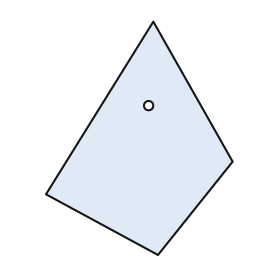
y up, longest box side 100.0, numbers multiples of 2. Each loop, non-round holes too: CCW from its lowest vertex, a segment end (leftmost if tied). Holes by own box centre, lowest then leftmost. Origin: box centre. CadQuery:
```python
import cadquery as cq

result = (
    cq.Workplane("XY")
    .moveTo(8.0, -50.0)
    .lineTo(40.0, -10.0)
    .lineTo(6.0, 50.0)
    .lineTo(-40.0, -24.0)
    .close()
    .moveTo(4.0, 14.0)
    .circle(2.0)
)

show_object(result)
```